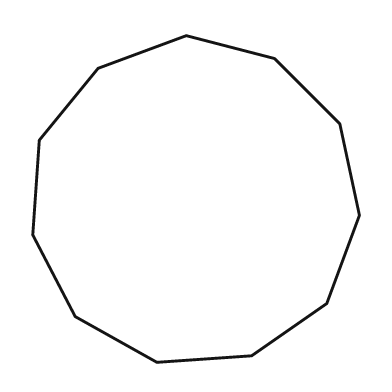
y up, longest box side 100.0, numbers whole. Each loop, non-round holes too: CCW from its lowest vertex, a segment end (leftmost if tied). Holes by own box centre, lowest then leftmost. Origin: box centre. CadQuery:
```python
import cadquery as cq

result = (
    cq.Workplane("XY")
    .moveTo(-12.0, -50.0)
    .lineTo(17.0, -48.0)
    .lineTo(40.0, -32.0)
    .lineTo(50.0, -5.0)
    .lineTo(44.0, 23.0)
    .lineTo(24.0, 43.0)
    .lineTo(-3.0, 50.0)
    .lineTo(-30.0, 40.0)
    .lineTo(-48.0, 18.0)
    .lineTo(-50.0, -11.0)
    .lineTo(-37.0, -36.0)
    .close()
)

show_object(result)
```